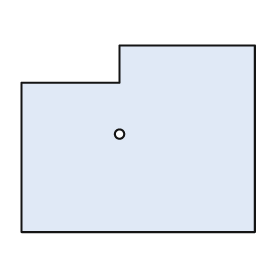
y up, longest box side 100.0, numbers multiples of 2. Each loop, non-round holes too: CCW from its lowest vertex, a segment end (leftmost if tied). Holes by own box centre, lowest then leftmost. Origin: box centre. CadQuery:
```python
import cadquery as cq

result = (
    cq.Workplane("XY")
    .moveTo(-50.0, -40.0)
    .lineTo(50.0, -40.0)
    .lineTo(50.0, 40.0)
    .lineTo(-8.0, 40.0)
    .lineTo(-8.0, 24.0)
    .lineTo(-50.0, 24.0)
    .close()
    .moveTo(-8.0, 2.0)
    .circle(2.0)
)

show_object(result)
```